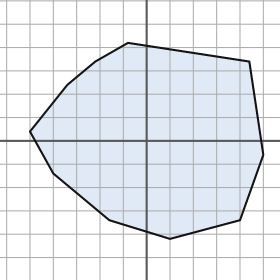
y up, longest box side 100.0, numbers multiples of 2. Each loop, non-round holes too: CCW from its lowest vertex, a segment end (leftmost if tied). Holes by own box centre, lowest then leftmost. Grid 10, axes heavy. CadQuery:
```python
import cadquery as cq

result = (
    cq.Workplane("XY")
    .moveTo(10.0, -42.0)
    .lineTo(40.0, -34.0)
    .lineTo(50.0, -6.0)
    .lineTo(44.0, 34.0)
    .lineTo(-8.0, 42.0)
    .lineTo(-22.0, 34.0)
    .lineTo(-34.0, 24.0)
    .lineTo(-50.0, 4.0)
    .lineTo(-40.0, -14.0)
    .lineTo(-16.0, -34.0)
    .close()
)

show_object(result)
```